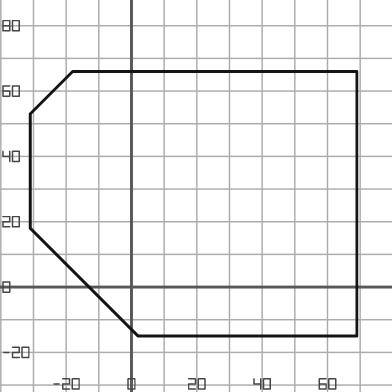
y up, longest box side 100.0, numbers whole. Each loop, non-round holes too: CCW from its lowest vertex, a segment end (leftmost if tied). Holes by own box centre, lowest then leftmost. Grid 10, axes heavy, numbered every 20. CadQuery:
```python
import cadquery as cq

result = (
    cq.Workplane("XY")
    .moveTo(2.0, -15.0)
    .lineTo(69.0, -15.0)
    .lineTo(69.0, 66.0)
    .lineTo(-18.0, 66.0)
    .lineTo(-31.0, 53.0)
    .lineTo(-31.0, 18.0)
    .close()
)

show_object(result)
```